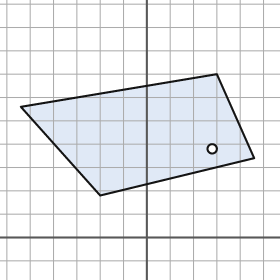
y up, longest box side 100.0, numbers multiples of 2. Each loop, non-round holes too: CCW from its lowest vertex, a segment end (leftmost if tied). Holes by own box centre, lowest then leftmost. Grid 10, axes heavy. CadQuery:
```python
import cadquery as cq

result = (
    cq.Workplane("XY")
    .moveTo(-20.0, 18.0)
    .lineTo(46.0, 34.0)
    .lineTo(30.0, 70.0)
    .lineTo(-54.0, 56.0)
    .close()
    .moveTo(28.0, 38.0)
    .circle(2.0)
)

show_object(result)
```